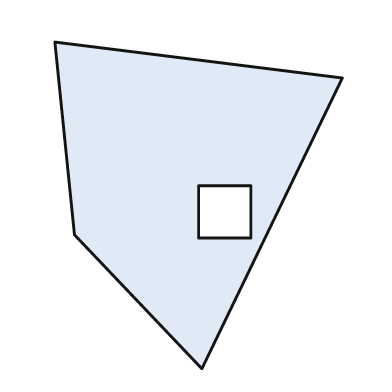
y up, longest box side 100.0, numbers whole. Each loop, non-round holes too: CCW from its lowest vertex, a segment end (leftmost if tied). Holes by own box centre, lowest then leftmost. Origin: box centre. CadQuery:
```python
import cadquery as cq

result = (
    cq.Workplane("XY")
    .moveTo(1.0, -50.0)
    .lineTo(44.0, 39.0)
    .lineTo(-44.0, 50.0)
    .lineTo(-38.0, -9.0)
    .close()
    .moveTo(0.0, -10.0)
    .lineTo(16.0, -10.0)
    .lineTo(16.0, 6.0)
    .lineTo(0.0, 6.0)
    .close()
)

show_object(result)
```